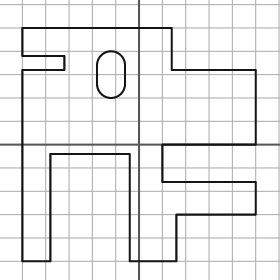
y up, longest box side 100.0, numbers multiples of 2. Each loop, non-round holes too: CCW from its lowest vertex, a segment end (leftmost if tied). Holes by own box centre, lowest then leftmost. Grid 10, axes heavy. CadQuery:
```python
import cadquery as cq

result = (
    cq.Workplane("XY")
    .moveTo(-50.0, -50.0)
    .lineTo(-38.0, -50.0)
    .lineTo(-38.0, -4.0)
    .lineTo(-4.0, -4.0)
    .lineTo(-4.0, -50.0)
    .lineTo(16.0, -50.0)
    .lineTo(16.0, -30.0)
    .lineTo(50.0, -30.0)
    .lineTo(50.0, -16.0)
    .lineTo(10.0, -16.0)
    .lineTo(10.0, 0.0)
    .lineTo(50.0, 0.0)
    .lineTo(50.0, 32.0)
    .lineTo(14.0, 32.0)
    .lineTo(14.0, 50.0)
    .lineTo(-50.0, 50.0)
    .lineTo(-50.0, 38.0)
    .lineTo(-32.0, 38.0)
    .lineTo(-32.0, 32.0)
    .lineTo(-50.0, 32.0)
    .close()
    .moveTo(-18.0, 26.0)
    .threePointArc((-12.0, 20.0), (-6.0, 26.0))
    .lineTo(-6.0, 34.0)
    .threePointArc((-12.0, 40.0), (-18.0, 34.0))
    .close()
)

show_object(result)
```